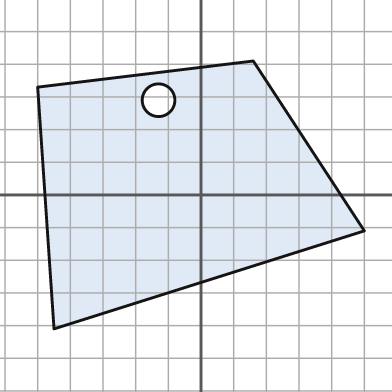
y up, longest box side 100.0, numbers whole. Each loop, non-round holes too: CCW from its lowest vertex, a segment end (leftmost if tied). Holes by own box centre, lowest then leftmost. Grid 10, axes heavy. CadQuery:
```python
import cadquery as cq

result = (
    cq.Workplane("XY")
    .moveTo(-45.0, -41.0)
    .lineTo(50.0, -11.0)
    .lineTo(16.0, 41.0)
    .lineTo(-50.0, 33.0)
    .close()
    .moveTo(-13.0, 29.0)
    .circle(5.0)
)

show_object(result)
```